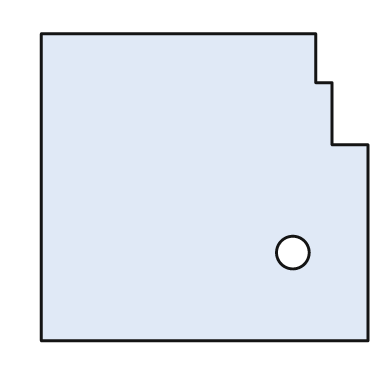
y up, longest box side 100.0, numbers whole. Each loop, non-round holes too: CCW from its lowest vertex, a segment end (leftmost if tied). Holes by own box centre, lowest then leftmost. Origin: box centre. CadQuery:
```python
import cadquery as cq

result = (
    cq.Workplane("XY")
    .moveTo(-50.0, -47.0)
    .lineTo(50.0, -47.0)
    .lineTo(50.0, 13.0)
    .lineTo(39.0, 13.0)
    .lineTo(39.0, 32.0)
    .lineTo(34.0, 32.0)
    .lineTo(34.0, 47.0)
    .lineTo(-50.0, 47.0)
    .close()
    .moveTo(27.0, -20.0)
    .circle(5.0)
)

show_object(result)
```